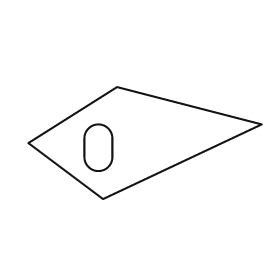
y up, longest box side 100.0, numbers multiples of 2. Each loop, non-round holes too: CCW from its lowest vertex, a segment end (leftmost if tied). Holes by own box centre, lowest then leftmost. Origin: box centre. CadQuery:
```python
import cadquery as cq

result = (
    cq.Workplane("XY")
    .moveTo(-18.0, -24.0)
    .lineTo(50.0, 8.0)
    .lineTo(-12.0, 24.0)
    .lineTo(-50.0, 0.0)
    .close()
    .moveTo(-26.0, -6.0)
    .threePointArc((-20.0, -12.0), (-14.0, -6.0))
    .lineTo(-14.0, 2.0)
    .threePointArc((-20.0, 8.0), (-26.0, 2.0))
    .close()
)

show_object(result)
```